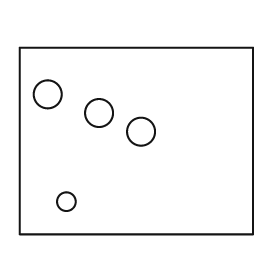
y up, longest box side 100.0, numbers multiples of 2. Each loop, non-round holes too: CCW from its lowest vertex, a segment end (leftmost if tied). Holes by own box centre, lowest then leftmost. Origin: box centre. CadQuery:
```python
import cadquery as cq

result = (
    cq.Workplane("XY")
    .moveTo(-50.0, -40.0)
    .lineTo(50.0, -40.0)
    .lineTo(50.0, 40.0)
    .lineTo(-50.0, 40.0)
    .close()
    .moveTo(-30.0, -26.0)
    .circle(4.0)
    .moveTo(2.0, 4.0)
    .circle(6.0)
    .moveTo(-16.0, 12.0)
    .circle(6.0)
    .moveTo(-38.0, 20.0)
    .circle(6.0)
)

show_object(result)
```